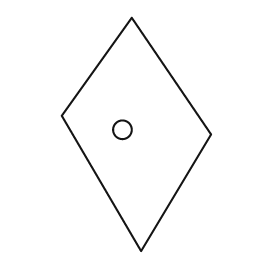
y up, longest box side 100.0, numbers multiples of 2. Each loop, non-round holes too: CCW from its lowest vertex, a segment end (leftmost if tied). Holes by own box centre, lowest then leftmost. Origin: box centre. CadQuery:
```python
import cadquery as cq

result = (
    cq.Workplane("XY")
    .moveTo(2.0, -50.0)
    .lineTo(32.0, 0.0)
    .lineTo(-2.0, 50.0)
    .lineTo(-32.0, 8.0)
    .close()
    .moveTo(-6.0, 2.0)
    .circle(4.0)
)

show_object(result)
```